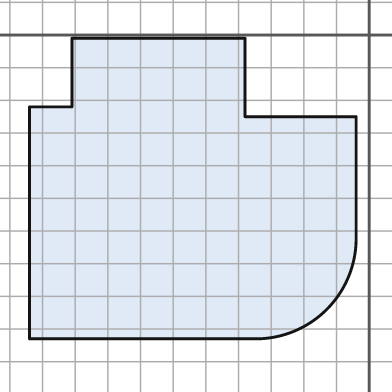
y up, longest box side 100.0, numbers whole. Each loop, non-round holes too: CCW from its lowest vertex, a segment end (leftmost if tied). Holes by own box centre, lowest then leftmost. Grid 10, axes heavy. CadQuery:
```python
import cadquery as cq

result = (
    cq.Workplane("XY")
    .moveTo(-104.0, -93.0)
    .lineTo(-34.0, -93.0)
    .threePointArc((-13.0, -84.0), (-4.0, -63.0))
    .lineTo(-4.0, -25.0)
    .lineTo(-38.0, -25.0)
    .lineTo(-38.0, -1.0)
    .lineTo(-91.0, -1.0)
    .lineTo(-91.0, -22.0)
    .lineTo(-104.0, -22.0)
    .close()
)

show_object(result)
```